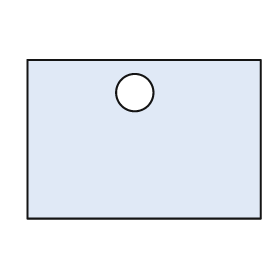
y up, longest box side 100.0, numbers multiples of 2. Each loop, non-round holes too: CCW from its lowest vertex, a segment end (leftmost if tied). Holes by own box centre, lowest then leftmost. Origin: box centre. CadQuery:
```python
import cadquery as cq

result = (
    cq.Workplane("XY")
    .moveTo(-50.0, -34.0)
    .lineTo(50.0, -34.0)
    .lineTo(50.0, 34.0)
    .lineTo(-50.0, 34.0)
    .close()
    .moveTo(-4.0, 20.0)
    .circle(8.0)
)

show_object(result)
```